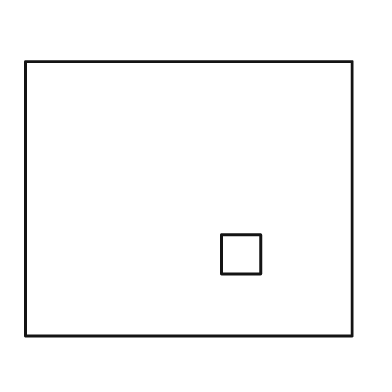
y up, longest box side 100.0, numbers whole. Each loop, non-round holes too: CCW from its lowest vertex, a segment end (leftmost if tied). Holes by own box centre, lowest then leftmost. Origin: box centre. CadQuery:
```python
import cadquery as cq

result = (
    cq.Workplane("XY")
    .moveTo(-50.0, -42.0)
    .lineTo(50.0, -42.0)
    .lineTo(50.0, 42.0)
    .lineTo(-50.0, 42.0)
    .close()
    .moveTo(10.0, -23.0)
    .lineTo(22.0, -23.0)
    .lineTo(22.0, -11.0)
    .lineTo(10.0, -11.0)
    .close()
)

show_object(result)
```